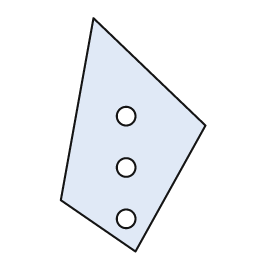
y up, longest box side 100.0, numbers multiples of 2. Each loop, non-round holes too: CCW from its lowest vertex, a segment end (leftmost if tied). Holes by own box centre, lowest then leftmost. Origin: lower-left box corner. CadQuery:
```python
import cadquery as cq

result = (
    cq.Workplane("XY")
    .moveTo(32.0, 0.0)
    .lineTo(62.0, 54.0)
    .lineTo(14.0, 100.0)
    .lineTo(0.0, 22.0)
    .close()
    .moveTo(28.0, 14.0)
    .circle(4.0)
    .moveTo(28.0, 36.0)
    .circle(4.0)
    .moveTo(28.0, 58.0)
    .circle(4.0)
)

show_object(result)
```